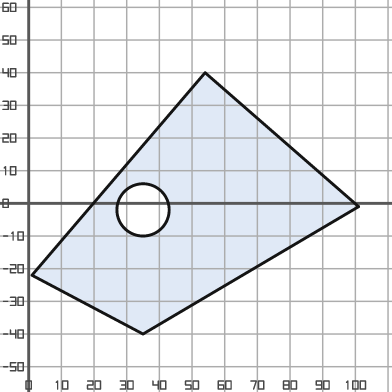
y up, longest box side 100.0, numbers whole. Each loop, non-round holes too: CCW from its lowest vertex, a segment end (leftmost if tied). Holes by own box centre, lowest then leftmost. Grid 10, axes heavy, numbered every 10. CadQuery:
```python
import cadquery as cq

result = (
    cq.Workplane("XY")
    .moveTo(35.0, -40.0)
    .lineTo(101.0, -1.0)
    .lineTo(54.0, 40.0)
    .lineTo(1.0, -22.0)
    .close()
    .moveTo(35.0, -2.0)
    .circle(8.0)
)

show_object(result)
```